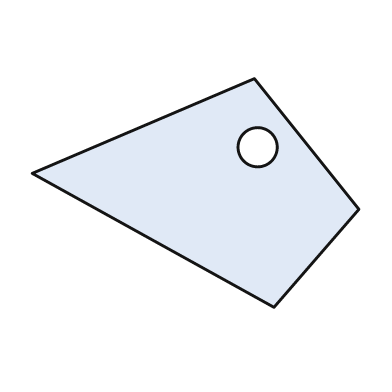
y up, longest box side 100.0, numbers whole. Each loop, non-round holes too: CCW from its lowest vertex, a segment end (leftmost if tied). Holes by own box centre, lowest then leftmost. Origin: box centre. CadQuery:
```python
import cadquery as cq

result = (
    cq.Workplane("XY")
    .moveTo(24.0, -35.0)
    .lineTo(50.0, -5.0)
    .lineTo(18.0, 35.0)
    .lineTo(-50.0, 6.0)
    .close()
    .moveTo(19.0, 14.0)
    .circle(6.0)
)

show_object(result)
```